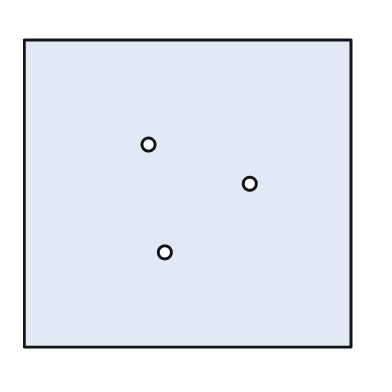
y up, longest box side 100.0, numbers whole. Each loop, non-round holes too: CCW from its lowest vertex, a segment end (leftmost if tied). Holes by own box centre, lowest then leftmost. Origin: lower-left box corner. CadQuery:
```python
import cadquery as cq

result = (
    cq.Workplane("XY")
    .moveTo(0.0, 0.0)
    .lineTo(100.0, 0.0)
    .lineTo(100.0, 94.0)
    .lineTo(0.0, 94.0)
    .close()
    .moveTo(43.0, 29.0)
    .circle(2.0)
    .moveTo(69.0, 50.0)
    .circle(2.0)
    .moveTo(38.0, 62.0)
    .circle(2.0)
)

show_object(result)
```